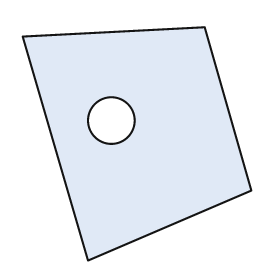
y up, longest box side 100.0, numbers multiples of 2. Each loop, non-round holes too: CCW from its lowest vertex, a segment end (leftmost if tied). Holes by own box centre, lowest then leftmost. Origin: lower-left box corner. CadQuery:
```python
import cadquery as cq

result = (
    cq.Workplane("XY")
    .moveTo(28.0, 0.0)
    .lineTo(98.0, 30.0)
    .lineTo(78.0, 100.0)
    .lineTo(0.0, 96.0)
    .close()
    .moveTo(38.0, 60.0)
    .circle(10.0)
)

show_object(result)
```